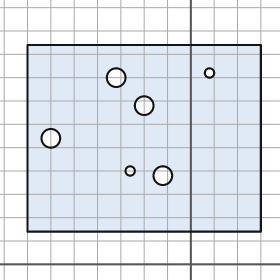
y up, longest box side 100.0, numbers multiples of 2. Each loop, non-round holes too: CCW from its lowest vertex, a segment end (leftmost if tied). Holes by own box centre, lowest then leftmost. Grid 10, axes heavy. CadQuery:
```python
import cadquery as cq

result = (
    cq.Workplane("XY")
    .moveTo(-70.0, 14.0)
    .lineTo(30.0, 14.0)
    .lineTo(30.0, 94.0)
    .lineTo(-70.0, 94.0)
    .close()
    .moveTo(-12.0, 38.0)
    .circle(4.0)
    .moveTo(-26.0, 40.0)
    .circle(2.0)
    .moveTo(-60.0, 54.0)
    .circle(4.0)
    .moveTo(-20.0, 68.0)
    .circle(4.0)
    .moveTo(-32.0, 80.0)
    .circle(4.0)
    .moveTo(8.0, 82.0)
    .circle(2.0)
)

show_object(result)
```